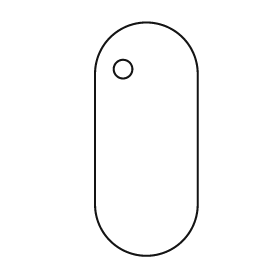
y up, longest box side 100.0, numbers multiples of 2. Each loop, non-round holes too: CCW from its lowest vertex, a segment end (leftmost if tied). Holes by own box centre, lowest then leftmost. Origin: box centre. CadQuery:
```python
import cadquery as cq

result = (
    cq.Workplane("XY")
    .moveTo(-22.0, -28.0)
    .threePointArc((0.0, -50.0), (22.0, -28.0))
    .lineTo(22.0, 28.0)
    .threePointArc((0.0, 50.0), (-22.0, 28.0))
    .close()
    .moveTo(-10.0, 30.0)
    .circle(4.0)
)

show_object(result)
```